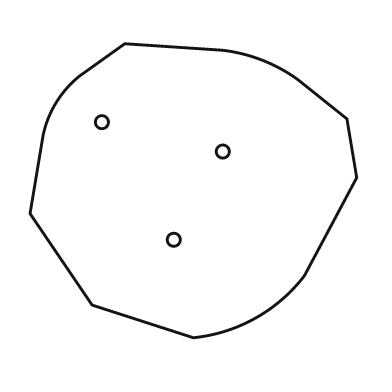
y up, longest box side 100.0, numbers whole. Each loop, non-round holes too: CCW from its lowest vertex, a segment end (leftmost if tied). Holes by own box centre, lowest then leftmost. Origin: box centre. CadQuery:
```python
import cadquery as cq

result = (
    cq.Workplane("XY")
    .moveTo(0.0, -45.0)
    .threePointArc((19.0, -39.0), (34.0, -26.0))
    .lineTo(50.0, 4.0)
    .lineTo(47.0, 22.0)
    .lineTo(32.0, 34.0)
    .threePointArc((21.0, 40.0), (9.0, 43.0))
    .lineTo(-21.0, 45.0)
    .lineTo(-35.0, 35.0)
    .threePointArc((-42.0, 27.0), (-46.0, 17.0))
    .lineTo(-50.0, -7.0)
    .lineTo(-31.0, -35.0)
    .close()
    .moveTo(-6.0, -15.0)
    .circle(2.0)
    .moveTo(9.0, 12.0)
    .circle(2.0)
    .moveTo(-28.0, 21.0)
    .circle(2.0)
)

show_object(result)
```